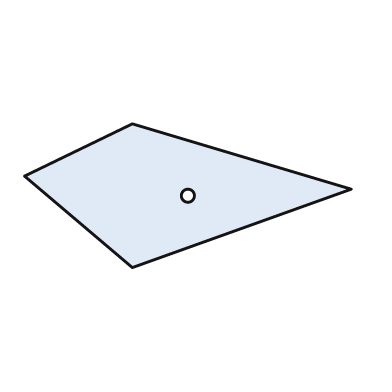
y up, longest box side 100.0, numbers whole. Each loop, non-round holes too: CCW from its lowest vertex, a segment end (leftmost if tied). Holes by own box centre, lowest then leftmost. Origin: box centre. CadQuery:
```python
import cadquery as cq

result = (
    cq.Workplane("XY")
    .moveTo(-17.0, -22.0)
    .lineTo(50.0, 2.0)
    .lineTo(-17.0, 22.0)
    .lineTo(-50.0, 6.0)
    .close()
    .moveTo(0.0, 0.0)
    .circle(2.0)
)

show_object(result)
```